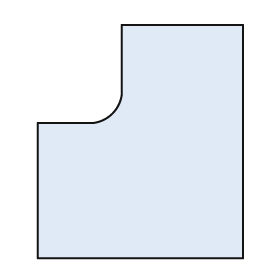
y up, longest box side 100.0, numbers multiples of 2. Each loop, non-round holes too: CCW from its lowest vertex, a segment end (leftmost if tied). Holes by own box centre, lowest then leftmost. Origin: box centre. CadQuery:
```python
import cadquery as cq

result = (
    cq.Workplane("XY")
    .moveTo(-44.0, -50.0)
    .lineTo(44.0, -50.0)
    .lineTo(44.0, 50.0)
    .lineTo(-8.0, 50.0)
    .lineTo(-8.0, 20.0)
    .threePointArc((-12.0, 12.0), (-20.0, 8.0))
    .lineTo(-44.0, 8.0)
    .close()
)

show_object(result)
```